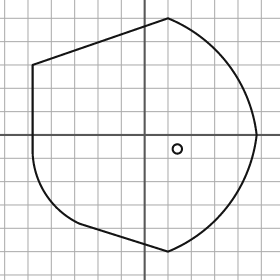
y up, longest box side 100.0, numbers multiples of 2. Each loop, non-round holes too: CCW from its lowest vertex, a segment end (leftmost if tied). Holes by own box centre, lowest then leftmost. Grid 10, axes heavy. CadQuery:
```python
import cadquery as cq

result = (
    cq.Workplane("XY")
    .moveTo(10.0, -50.0)
    .threePointArc((36.0, -30.0), (48.0, 0.0))
    .threePointArc((36.0, 30.0), (10.0, 50.0))
    .lineTo(-48.0, 30.0)
    .lineTo(-48.0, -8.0)
    .threePointArc((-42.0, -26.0), (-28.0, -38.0))
    .close()
    .moveTo(14.0, -6.0)
    .circle(2.0)
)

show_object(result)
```